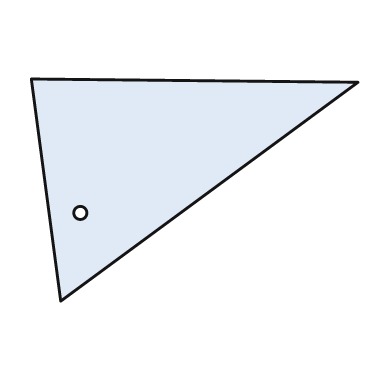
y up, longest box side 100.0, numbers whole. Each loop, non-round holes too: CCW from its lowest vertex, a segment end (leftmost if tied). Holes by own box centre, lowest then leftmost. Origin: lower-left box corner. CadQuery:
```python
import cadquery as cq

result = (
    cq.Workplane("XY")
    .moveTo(9.0, 0.0)
    .lineTo(100.0, 67.0)
    .lineTo(0.0, 68.0)
    .close()
    .moveTo(15.0, 27.0)
    .circle(2.0)
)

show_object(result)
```